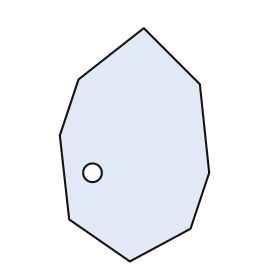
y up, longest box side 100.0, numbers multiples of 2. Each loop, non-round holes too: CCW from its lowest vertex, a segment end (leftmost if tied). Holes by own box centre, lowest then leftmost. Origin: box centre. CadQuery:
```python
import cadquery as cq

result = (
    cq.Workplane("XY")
    .moveTo(-2.0, -50.0)
    .lineTo(24.0, -36.0)
    .lineTo(32.0, -12.0)
    .lineTo(28.0, 26.0)
    .lineTo(4.0, 50.0)
    .lineTo(-24.0, 28.0)
    .lineTo(-32.0, 4.0)
    .lineTo(-28.0, -32.0)
    .close()
    .moveTo(-18.0, -12.0)
    .circle(4.0)
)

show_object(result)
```